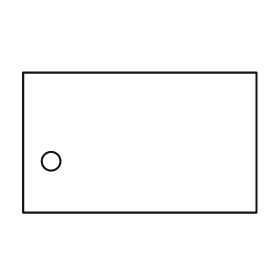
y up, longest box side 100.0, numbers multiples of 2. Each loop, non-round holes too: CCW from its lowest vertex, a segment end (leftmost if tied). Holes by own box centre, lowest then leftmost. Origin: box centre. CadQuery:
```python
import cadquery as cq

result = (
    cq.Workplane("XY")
    .moveTo(-50.0, -30.0)
    .lineTo(50.0, -30.0)
    .lineTo(50.0, 30.0)
    .lineTo(-50.0, 30.0)
    .close()
    .moveTo(-38.0, -8.0)
    .circle(4.0)
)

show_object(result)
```